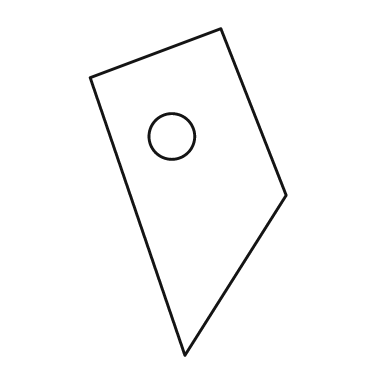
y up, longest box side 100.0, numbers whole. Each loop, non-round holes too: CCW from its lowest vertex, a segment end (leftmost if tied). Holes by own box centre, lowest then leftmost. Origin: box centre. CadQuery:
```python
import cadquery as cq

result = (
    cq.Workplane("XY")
    .moveTo(-1.0, -50.0)
    .lineTo(30.0, -1.0)
    .lineTo(10.0, 50.0)
    .lineTo(-30.0, 35.0)
    .close()
    .moveTo(-5.0, 17.0)
    .circle(7.0)
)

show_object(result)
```